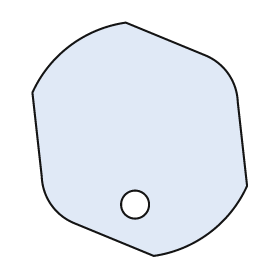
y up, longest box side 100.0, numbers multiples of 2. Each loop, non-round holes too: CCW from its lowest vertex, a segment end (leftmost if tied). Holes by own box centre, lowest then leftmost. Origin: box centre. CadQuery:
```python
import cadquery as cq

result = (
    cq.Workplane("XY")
    .moveTo(6.0, -50.0)
    .threePointArc((30.0, -40.0), (46.0, -20.0))
    .lineTo(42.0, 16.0)
    .threePointArc((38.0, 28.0), (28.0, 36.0))
    .lineTo(-6.0, 50.0)
    .threePointArc((-30.0, 40.0), (-46.0, 20.0))
    .lineTo(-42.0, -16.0)
    .threePointArc((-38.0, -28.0), (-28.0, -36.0))
    .close()
    .moveTo(-2.0, -28.0)
    .circle(6.0)
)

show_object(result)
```